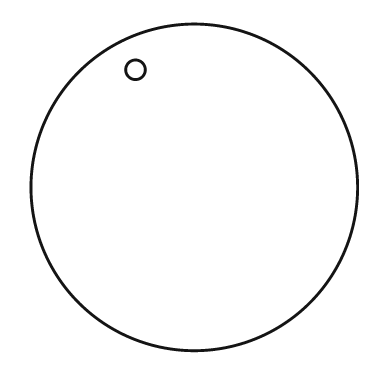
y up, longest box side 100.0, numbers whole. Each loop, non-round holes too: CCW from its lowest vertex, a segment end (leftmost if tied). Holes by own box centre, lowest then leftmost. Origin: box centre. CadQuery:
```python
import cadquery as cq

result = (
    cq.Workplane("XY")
    .moveTo(0.0, 0.0)
    .circle(50.0)
    .moveTo(-18.0, 36.0)
    .circle(3.0)
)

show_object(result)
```